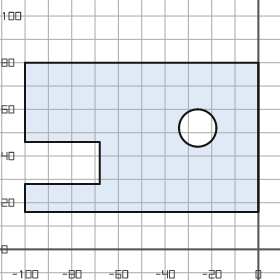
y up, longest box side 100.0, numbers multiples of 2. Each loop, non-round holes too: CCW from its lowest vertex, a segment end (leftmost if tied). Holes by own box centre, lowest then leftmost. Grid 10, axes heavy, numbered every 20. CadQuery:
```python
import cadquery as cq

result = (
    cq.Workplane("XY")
    .moveTo(-100.0, 16.0)
    .lineTo(0.0, 16.0)
    .lineTo(0.0, 80.0)
    .lineTo(-100.0, 80.0)
    .lineTo(-100.0, 46.0)
    .lineTo(-68.0, 46.0)
    .lineTo(-68.0, 28.0)
    .lineTo(-100.0, 28.0)
    .close()
    .moveTo(-26.0, 52.0)
    .circle(8.0)
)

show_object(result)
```